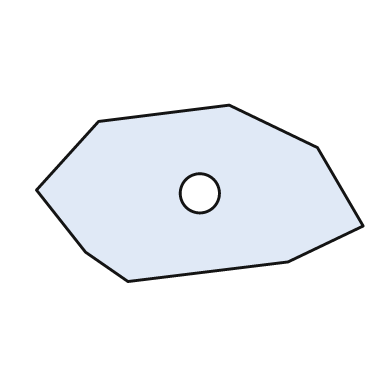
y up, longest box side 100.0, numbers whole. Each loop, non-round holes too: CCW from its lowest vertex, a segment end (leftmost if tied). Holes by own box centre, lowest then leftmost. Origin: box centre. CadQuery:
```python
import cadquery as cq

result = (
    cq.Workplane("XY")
    .moveTo(-22.0, -27.0)
    .lineTo(27.0, -21.0)
    .lineTo(50.0, -10.0)
    .lineTo(36.0, 14.0)
    .lineTo(9.0, 27.0)
    .lineTo(-31.0, 22.0)
    .lineTo(-50.0, 1.0)
    .lineTo(-35.0, -18.0)
    .close()
    .moveTo(0.0, 0.0)
    .circle(6.0)
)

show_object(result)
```